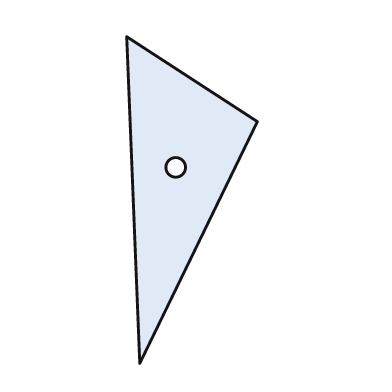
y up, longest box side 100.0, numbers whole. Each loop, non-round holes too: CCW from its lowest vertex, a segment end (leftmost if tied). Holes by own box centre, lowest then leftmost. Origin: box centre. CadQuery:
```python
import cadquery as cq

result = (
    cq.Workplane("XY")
    .moveTo(-16.0, -50.0)
    .lineTo(20.0, 24.0)
    .lineTo(-20.0, 50.0)
    .close()
    .moveTo(-5.0, 10.0)
    .circle(3.0)
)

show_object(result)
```